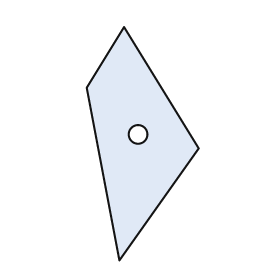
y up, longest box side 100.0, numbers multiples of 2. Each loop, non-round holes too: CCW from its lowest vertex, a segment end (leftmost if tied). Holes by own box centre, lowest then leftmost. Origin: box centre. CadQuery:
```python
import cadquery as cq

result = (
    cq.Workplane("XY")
    .moveTo(-10.0, -50.0)
    .lineTo(24.0, -2.0)
    .lineTo(-8.0, 50.0)
    .lineTo(-24.0, 24.0)
    .close()
    .moveTo(-2.0, 4.0)
    .circle(4.0)
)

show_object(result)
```